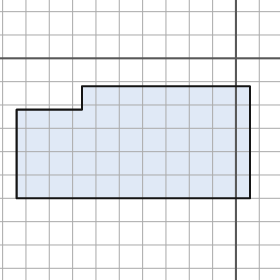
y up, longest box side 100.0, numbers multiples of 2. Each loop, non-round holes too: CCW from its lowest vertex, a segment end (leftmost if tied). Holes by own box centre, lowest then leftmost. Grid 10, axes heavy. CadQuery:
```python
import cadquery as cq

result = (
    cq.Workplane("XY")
    .moveTo(-94.0, -60.0)
    .lineTo(6.0, -60.0)
    .lineTo(6.0, -12.0)
    .lineTo(-66.0, -12.0)
    .lineTo(-66.0, -22.0)
    .lineTo(-94.0, -22.0)
    .close()
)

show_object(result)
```